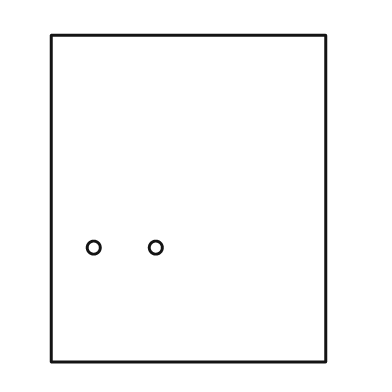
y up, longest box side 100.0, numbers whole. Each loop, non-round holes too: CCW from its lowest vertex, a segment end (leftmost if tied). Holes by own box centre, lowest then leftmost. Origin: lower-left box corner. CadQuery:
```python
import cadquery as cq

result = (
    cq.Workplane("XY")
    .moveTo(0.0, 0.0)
    .lineTo(84.0, 0.0)
    .lineTo(84.0, 100.0)
    .lineTo(0.0, 100.0)
    .close()
    .moveTo(13.0, 35.0)
    .circle(2.0)
    .moveTo(32.0, 35.0)
    .circle(2.0)
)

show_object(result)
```